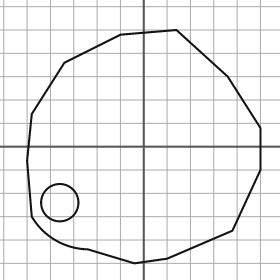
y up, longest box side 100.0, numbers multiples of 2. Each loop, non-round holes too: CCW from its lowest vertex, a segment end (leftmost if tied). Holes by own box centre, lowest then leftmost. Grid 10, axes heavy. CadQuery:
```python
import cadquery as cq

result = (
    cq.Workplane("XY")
    .moveTo(-4.0, -50.0)
    .lineTo(10.0, -48.0)
    .lineTo(38.0, -36.0)
    .lineTo(50.0, -10.0)
    .lineTo(50.0, 8.0)
    .lineTo(36.0, 30.0)
    .lineTo(14.0, 50.0)
    .lineTo(-10.0, 48.0)
    .lineTo(-34.0, 36.0)
    .lineTo(-48.0, 14.0)
    .lineTo(-50.0, -6.0)
    .lineTo(-48.0, -30.0)
    .threePointArc((-38.0, -40.0), (-24.0, -44.0))
    .close()
    .moveTo(-36.0, -24.0)
    .circle(8.0)
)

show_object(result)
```